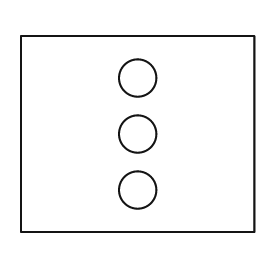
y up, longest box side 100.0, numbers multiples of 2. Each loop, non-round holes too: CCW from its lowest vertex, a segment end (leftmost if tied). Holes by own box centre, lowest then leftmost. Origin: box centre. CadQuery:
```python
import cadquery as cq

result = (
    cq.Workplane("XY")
    .moveTo(-50.0, -42.0)
    .lineTo(50.0, -42.0)
    .lineTo(50.0, 42.0)
    .lineTo(-50.0, 42.0)
    .close()
    .moveTo(0.0, -24.0)
    .circle(8.0)
    .moveTo(0.0, 0.0)
    .circle(8.0)
    .moveTo(0.0, 24.0)
    .circle(8.0)
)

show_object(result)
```